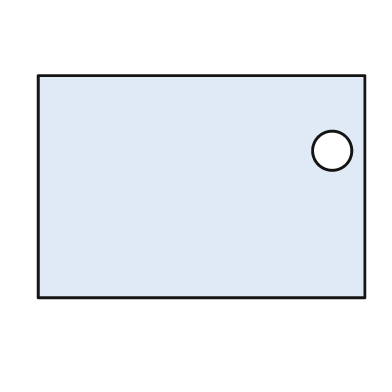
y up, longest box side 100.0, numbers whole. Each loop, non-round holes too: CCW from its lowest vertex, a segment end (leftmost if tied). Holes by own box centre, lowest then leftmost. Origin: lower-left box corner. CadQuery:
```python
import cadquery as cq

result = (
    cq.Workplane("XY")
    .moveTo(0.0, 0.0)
    .lineTo(100.0, 0.0)
    .lineTo(100.0, 68.0)
    .lineTo(0.0, 68.0)
    .close()
    .moveTo(90.0, 45.0)
    .circle(6.0)
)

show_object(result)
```